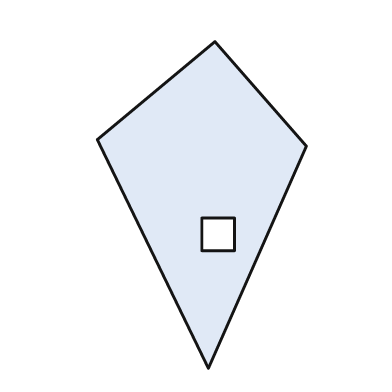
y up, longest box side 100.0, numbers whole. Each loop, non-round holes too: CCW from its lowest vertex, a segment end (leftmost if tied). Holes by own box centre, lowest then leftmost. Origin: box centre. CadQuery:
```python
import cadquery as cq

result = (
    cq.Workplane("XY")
    .moveTo(2.0, -50.0)
    .lineTo(32.0, 18.0)
    .lineTo(4.0, 50.0)
    .lineTo(-32.0, 20.0)
    .close()
    .moveTo(0.0, -14.0)
    .lineTo(10.0, -14.0)
    .lineTo(10.0, -4.0)
    .lineTo(0.0, -4.0)
    .close()
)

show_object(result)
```